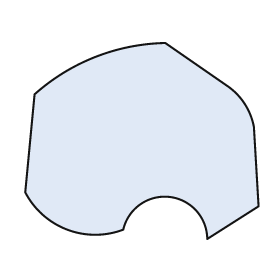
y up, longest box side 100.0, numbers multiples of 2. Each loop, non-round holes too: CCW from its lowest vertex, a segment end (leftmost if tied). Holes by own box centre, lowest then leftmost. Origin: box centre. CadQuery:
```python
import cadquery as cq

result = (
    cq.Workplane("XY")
    .moveTo(28.0, -42.0)
    .lineTo(50.0, -28.0)
    .lineTo(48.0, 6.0)
    .threePointArc((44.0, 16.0), (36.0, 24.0))
    .lineTo(10.0, 42.0)
    .threePointArc((-20.0, 36.0), (-46.0, 20.0))
    .lineTo(-50.0, -22.0)
    .threePointArc((-32.0, -38.0), (-8.0, -38.0))
    .threePointArc((12.0, -24.0), (28.0, -42.0))
    .close()
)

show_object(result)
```